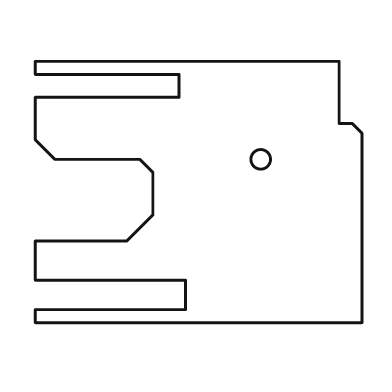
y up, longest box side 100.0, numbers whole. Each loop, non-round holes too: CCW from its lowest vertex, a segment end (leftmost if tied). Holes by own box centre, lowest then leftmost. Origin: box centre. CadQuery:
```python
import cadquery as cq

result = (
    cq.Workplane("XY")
    .moveTo(-50.0, -40.0)
    .lineTo(50.0, -40.0)
    .lineTo(50.0, 18.0)
    .lineTo(47.0, 21.0)
    .lineTo(43.0, 21.0)
    .lineTo(43.0, 40.0)
    .lineTo(-50.0, 40.0)
    .lineTo(-50.0, 36.0)
    .lineTo(-6.0, 36.0)
    .lineTo(-6.0, 29.0)
    .lineTo(-50.0, 29.0)
    .lineTo(-50.0, 16.0)
    .lineTo(-44.0, 10.0)
    .lineTo(-18.0, 10.0)
    .lineTo(-14.0, 6.0)
    .lineTo(-14.0, -7.0)
    .lineTo(-22.0, -15.0)
    .lineTo(-50.0, -15.0)
    .lineTo(-50.0, -27.0)
    .lineTo(-4.0, -27.0)
    .lineTo(-4.0, -36.0)
    .lineTo(-50.0, -36.0)
    .close()
    .moveTo(19.0, 10.0)
    .circle(3.0)
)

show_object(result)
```